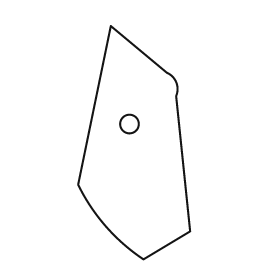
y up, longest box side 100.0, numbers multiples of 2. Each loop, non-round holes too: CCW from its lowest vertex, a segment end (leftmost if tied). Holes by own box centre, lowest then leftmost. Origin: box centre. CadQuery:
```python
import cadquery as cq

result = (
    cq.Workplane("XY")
    .moveTo(4.0, -50.0)
    .lineTo(24.0, -38.0)
    .lineTo(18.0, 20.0)
    .threePointArc((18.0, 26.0), (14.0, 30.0))
    .lineTo(-10.0, 50.0)
    .lineTo(-24.0, -18.0)
    .threePointArc((-12.0, -36.0), (4.0, -50.0))
    .close()
    .moveTo(-2.0, 8.0)
    .circle(4.0)
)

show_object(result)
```